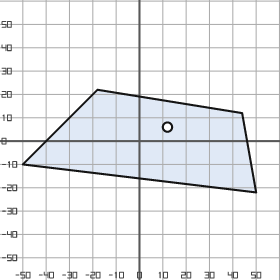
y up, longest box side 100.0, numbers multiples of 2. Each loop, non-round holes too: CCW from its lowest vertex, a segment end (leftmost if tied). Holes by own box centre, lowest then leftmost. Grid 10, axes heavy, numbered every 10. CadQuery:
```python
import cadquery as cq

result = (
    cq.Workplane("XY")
    .moveTo(50.0, -22.0)
    .lineTo(44.0, 12.0)
    .lineTo(-18.0, 22.0)
    .lineTo(-50.0, -10.0)
    .close()
    .moveTo(12.0, 6.0)
    .circle(2.0)
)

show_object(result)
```